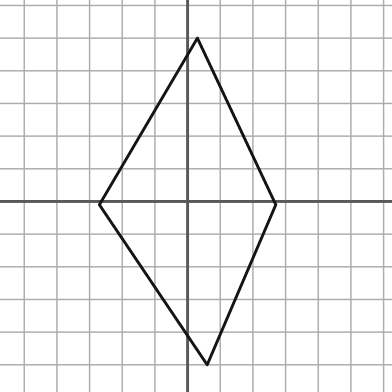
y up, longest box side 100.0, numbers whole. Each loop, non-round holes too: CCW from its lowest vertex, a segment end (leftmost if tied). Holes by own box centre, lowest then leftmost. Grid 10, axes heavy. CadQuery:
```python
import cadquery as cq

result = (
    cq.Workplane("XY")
    .moveTo(6.0, -50.0)
    .lineTo(27.0, -1.0)
    .lineTo(3.0, 50.0)
    .lineTo(-27.0, -1.0)
    .close()
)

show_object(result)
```